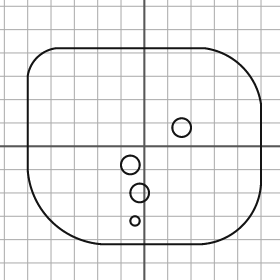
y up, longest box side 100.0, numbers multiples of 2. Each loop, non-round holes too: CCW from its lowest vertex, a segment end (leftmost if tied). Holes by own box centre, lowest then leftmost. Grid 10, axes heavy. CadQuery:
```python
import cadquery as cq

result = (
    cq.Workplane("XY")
    .moveTo(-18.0, -42.0)
    .lineTo(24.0, -42.0)
    .threePointArc((42.0, -34.0), (50.0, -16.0))
    .lineTo(50.0, 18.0)
    .threePointArc((42.0, 34.0), (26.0, 42.0))
    .lineTo(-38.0, 42.0)
    .threePointArc((-46.0, 38.0), (-50.0, 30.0))
    .lineTo(-50.0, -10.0)
    .threePointArc((-40.0, -32.0), (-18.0, -42.0))
    .close()
    .moveTo(-4.0, -32.0)
    .circle(2.0)
    .moveTo(-2.0, -20.0)
    .circle(4.0)
    .moveTo(-6.0, -8.0)
    .circle(4.0)
    .moveTo(16.0, 8.0)
    .circle(4.0)
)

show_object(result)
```